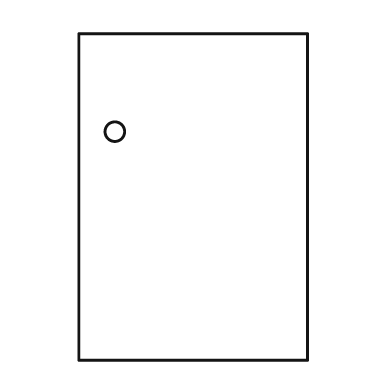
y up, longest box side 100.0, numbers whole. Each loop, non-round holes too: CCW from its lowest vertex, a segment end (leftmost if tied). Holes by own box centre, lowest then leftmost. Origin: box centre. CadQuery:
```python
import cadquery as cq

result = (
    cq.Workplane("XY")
    .moveTo(-35.0, -50.0)
    .lineTo(35.0, -50.0)
    .lineTo(35.0, 50.0)
    .lineTo(-35.0, 50.0)
    .close()
    .moveTo(-24.0, 20.0)
    .circle(3.0)
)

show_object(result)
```